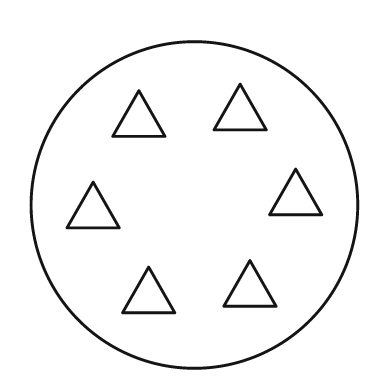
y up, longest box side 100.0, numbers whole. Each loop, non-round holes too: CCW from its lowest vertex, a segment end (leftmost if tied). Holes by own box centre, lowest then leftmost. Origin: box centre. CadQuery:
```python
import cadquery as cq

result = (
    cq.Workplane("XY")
    .moveTo(0.0, 0.0)
    .circle(50.0)
    .moveTo(-22.0, -33.0)
    .lineTo(-6.0, -33.0)
    .lineTo(-14.0, -19.0)
    .close()
    .moveTo(9.0, -31.0)
    .lineTo(25.0, -31.0)
    .lineTo(17.0, -17.0)
    .close()
    .moveTo(-39.0, -7.0)
    .lineTo(-23.0, -7.0)
    .lineTo(-31.0, 7.0)
    .close()
    .moveTo(23.0, -3.0)
    .lineTo(39.0, -3.0)
    .lineTo(31.0, 11.0)
    .close()
    .moveTo(-25.0, 21.0)
    .lineTo(-9.0, 21.0)
    .lineTo(-17.0, 35.0)
    .close()
    .moveTo(6.0, 23.0)
    .lineTo(22.0, 23.0)
    .lineTo(14.0, 37.0)
    .close()
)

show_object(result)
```